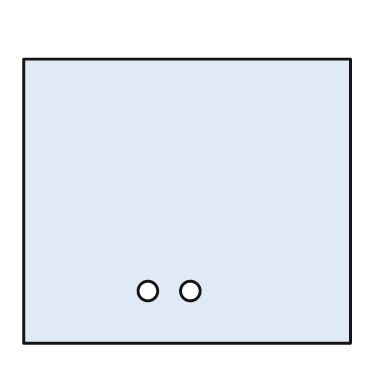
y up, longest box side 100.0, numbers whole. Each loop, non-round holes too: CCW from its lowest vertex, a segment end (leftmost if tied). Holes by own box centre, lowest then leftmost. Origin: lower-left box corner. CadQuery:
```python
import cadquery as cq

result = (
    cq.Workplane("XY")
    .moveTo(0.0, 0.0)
    .lineTo(100.0, 0.0)
    .lineTo(100.0, 87.0)
    .lineTo(0.0, 87.0)
    .close()
    .moveTo(38.0, 16.0)
    .circle(3.0)
    .moveTo(51.0, 16.0)
    .circle(3.0)
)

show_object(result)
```